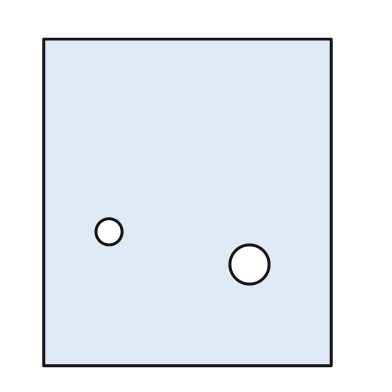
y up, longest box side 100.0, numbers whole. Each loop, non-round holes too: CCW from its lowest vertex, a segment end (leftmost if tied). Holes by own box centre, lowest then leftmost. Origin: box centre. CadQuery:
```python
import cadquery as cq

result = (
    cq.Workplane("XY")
    .moveTo(-44.0, -50.0)
    .lineTo(44.0, -50.0)
    .lineTo(44.0, 50.0)
    .lineTo(-44.0, 50.0)
    .close()
    .moveTo(19.0, -19.0)
    .circle(6.0)
    .moveTo(-24.0, -9.0)
    .circle(4.0)
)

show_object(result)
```